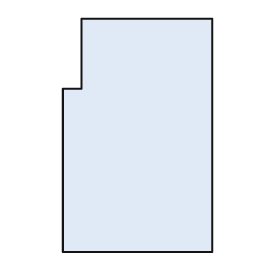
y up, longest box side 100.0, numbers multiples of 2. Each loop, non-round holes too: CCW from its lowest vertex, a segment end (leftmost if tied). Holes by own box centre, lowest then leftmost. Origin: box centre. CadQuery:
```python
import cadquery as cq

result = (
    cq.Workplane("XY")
    .moveTo(-32.0, -50.0)
    .lineTo(32.0, -50.0)
    .lineTo(32.0, 50.0)
    .lineTo(-24.0, 50.0)
    .lineTo(-24.0, 20.0)
    .lineTo(-32.0, 20.0)
    .close()
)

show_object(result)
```